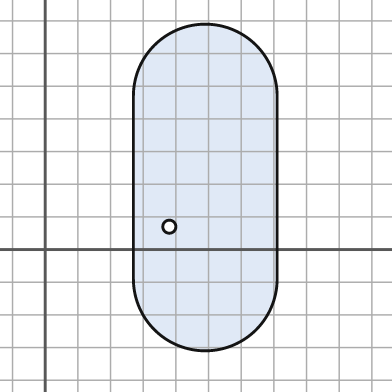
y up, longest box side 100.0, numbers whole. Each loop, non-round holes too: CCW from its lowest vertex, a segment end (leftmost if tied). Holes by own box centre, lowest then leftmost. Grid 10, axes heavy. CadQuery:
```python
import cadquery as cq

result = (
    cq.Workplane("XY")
    .moveTo(27.0, -9.0)
    .threePointArc((49.0, -31.0), (71.0, -9.0))
    .lineTo(71.0, 47.0)
    .threePointArc((49.0, 69.0), (27.0, 47.0))
    .close()
    .moveTo(38.0, 7.0)
    .circle(2.0)
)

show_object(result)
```